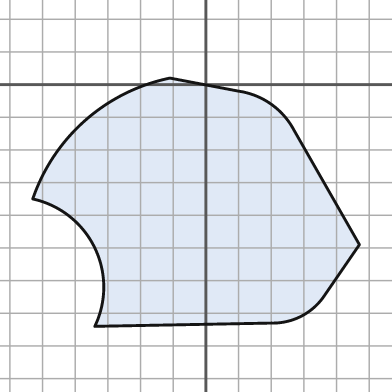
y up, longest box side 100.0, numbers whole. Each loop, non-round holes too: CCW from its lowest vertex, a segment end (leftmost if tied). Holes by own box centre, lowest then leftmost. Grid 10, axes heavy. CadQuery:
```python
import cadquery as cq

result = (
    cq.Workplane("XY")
    .moveTo(-34.0, -74.0)
    .lineTo(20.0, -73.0)
    .threePointArc((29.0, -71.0), (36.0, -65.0))
    .lineTo(47.0, -49.0)
    .lineTo(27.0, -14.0)
    .threePointArc((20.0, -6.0), (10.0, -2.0))
    .lineTo(-11.0, 2.0)
    .threePointArc((-37.0, -11.0), (-53.0, -35.0))
    .threePointArc((-34.0, -50.0), (-34.0, -74.0))
    .close()
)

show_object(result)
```